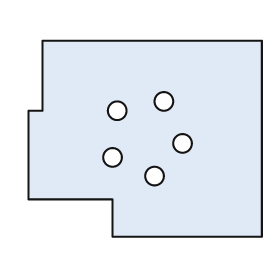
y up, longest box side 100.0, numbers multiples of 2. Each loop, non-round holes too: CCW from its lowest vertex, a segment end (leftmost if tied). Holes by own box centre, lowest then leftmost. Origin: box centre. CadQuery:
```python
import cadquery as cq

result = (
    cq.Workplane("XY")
    .moveTo(-14.0, -42.0)
    .lineTo(50.0, -42.0)
    .lineTo(50.0, 42.0)
    .lineTo(-44.0, 42.0)
    .lineTo(-44.0, 12.0)
    .lineTo(-50.0, 12.0)
    .lineTo(-50.0, -26.0)
    .lineTo(-14.0, -26.0)
    .close()
    .moveTo(4.0, -16.0)
    .circle(4.0)
    .moveTo(-14.0, -8.0)
    .circle(4.0)
    .moveTo(16.0, -2.0)
    .circle(4.0)
    .moveTo(-12.0, 12.0)
    .circle(4.0)
    .moveTo(8.0, 16.0)
    .circle(4.0)
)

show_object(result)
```